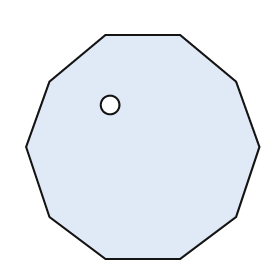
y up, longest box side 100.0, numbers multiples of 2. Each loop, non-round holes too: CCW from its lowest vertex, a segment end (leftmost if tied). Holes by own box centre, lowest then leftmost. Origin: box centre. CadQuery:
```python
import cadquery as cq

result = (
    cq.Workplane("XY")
    .moveTo(-16.0, -48.0)
    .lineTo(16.0, -48.0)
    .lineTo(40.0, -30.0)
    .lineTo(50.0, 0.0)
    .lineTo(40.0, 28.0)
    .lineTo(16.0, 48.0)
    .lineTo(-16.0, 48.0)
    .lineTo(-40.0, 28.0)
    .lineTo(-50.0, 0.0)
    .lineTo(-40.0, -30.0)
    .close()
    .moveTo(-14.0, 18.0)
    .circle(4.0)
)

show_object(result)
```